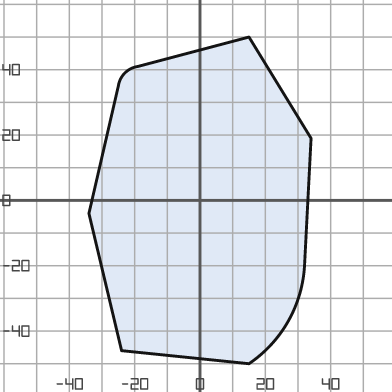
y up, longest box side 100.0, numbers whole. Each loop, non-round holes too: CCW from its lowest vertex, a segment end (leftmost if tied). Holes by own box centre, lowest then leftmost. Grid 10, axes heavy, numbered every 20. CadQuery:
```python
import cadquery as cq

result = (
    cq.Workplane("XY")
    .moveTo(15.0, -50.0)
    .threePointArc((27.0, -37.0), (32.0, -20.0))
    .lineTo(34.0, 19.0)
    .lineTo(15.0, 50.0)
    .lineTo(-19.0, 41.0)
    .threePointArc((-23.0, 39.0), (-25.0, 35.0))
    .lineTo(-34.0, -4.0)
    .lineTo(-24.0, -46.0)
    .close()
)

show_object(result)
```